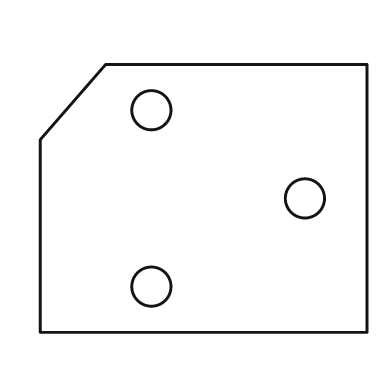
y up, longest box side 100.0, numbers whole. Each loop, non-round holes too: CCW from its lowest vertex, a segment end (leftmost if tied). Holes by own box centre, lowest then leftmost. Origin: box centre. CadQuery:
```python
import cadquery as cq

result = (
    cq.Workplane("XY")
    .moveTo(-50.0, -41.0)
    .lineTo(50.0, -41.0)
    .lineTo(50.0, 41.0)
    .lineTo(-30.0, 41.0)
    .lineTo(-50.0, 18.0)
    .close()
    .moveTo(-16.0, -27.0)
    .circle(6.0)
    .moveTo(31.0, 0.0)
    .circle(6.0)
    .moveTo(-16.0, 27.0)
    .circle(6.0)
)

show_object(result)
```